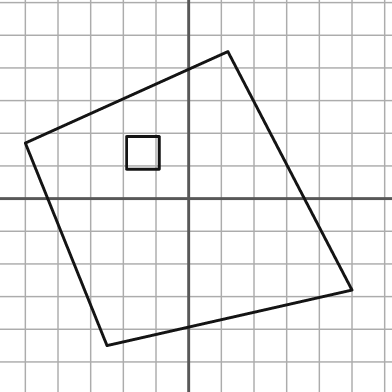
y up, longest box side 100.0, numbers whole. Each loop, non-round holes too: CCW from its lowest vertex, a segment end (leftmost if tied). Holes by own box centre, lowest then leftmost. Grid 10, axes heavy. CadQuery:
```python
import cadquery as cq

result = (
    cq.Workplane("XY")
    .moveTo(-25.0, -45.0)
    .lineTo(50.0, -28.0)
    .lineTo(12.0, 45.0)
    .lineTo(-50.0, 17.0)
    .close()
    .moveTo(-19.0, 9.0)
    .lineTo(-9.0, 9.0)
    .lineTo(-9.0, 19.0)
    .lineTo(-19.0, 19.0)
    .close()
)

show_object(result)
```